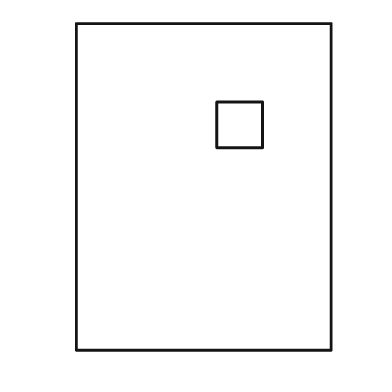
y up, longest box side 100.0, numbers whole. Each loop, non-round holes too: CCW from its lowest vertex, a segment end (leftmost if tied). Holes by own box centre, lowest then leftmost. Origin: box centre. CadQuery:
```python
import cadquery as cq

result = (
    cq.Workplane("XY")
    .moveTo(-39.0, -50.0)
    .lineTo(39.0, -50.0)
    .lineTo(39.0, 50.0)
    .lineTo(-39.0, 50.0)
    .close()
    .moveTo(4.0, 12.0)
    .lineTo(18.0, 12.0)
    .lineTo(18.0, 26.0)
    .lineTo(4.0, 26.0)
    .close()
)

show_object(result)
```